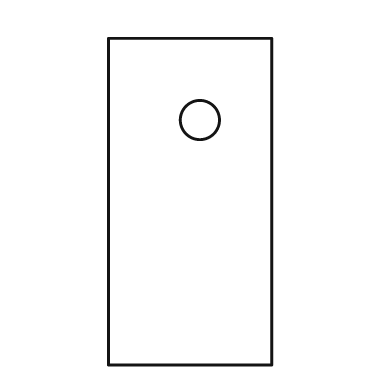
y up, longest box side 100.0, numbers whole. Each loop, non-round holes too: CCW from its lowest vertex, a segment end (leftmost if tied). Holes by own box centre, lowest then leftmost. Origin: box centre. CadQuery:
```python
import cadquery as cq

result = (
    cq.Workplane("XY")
    .moveTo(-25.0, -50.0)
    .lineTo(25.0, -50.0)
    .lineTo(25.0, 50.0)
    .lineTo(-25.0, 50.0)
    .close()
    .moveTo(3.0, 25.0)
    .circle(6.0)
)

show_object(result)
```